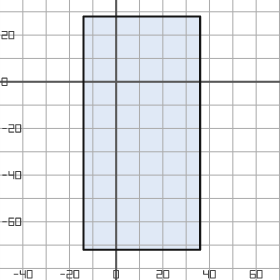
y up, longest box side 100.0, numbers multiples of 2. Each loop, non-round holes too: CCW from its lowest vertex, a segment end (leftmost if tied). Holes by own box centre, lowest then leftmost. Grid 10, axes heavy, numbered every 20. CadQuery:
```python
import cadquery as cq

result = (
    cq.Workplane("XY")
    .moveTo(-14.0, -72.0)
    .lineTo(36.0, -72.0)
    .lineTo(36.0, 28.0)
    .lineTo(-14.0, 28.0)
    .close()
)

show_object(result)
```